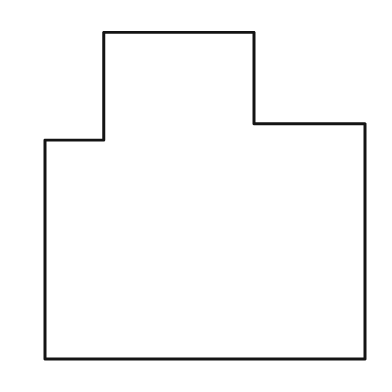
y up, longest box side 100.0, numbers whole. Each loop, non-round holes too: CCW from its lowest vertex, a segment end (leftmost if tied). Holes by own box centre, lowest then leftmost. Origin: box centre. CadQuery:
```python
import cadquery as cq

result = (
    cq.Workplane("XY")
    .moveTo(-49.0, -50.0)
    .lineTo(49.0, -50.0)
    .lineTo(49.0, 22.0)
    .lineTo(15.0, 22.0)
    .lineTo(15.0, 50.0)
    .lineTo(-31.0, 50.0)
    .lineTo(-31.0, 17.0)
    .lineTo(-49.0, 17.0)
    .close()
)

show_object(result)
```